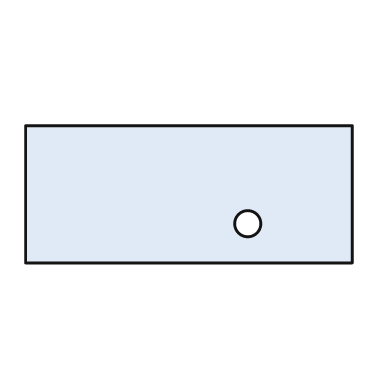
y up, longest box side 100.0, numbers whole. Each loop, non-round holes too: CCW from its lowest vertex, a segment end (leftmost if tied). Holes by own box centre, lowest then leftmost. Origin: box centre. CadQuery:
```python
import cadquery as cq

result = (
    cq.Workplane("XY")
    .moveTo(-50.0, -21.0)
    .lineTo(50.0, -21.0)
    .lineTo(50.0, 21.0)
    .lineTo(-50.0, 21.0)
    .close()
    .moveTo(18.0, -9.0)
    .circle(4.0)
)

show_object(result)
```